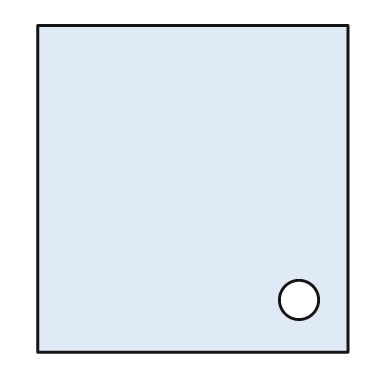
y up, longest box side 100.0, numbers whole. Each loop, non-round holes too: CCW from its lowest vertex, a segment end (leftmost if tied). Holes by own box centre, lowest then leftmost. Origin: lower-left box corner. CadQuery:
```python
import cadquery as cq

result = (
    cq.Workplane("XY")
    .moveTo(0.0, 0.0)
    .lineTo(95.0, 0.0)
    .lineTo(95.0, 100.0)
    .lineTo(0.0, 100.0)
    .close()
    .moveTo(80.0, 16.0)
    .circle(6.0)
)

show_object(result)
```